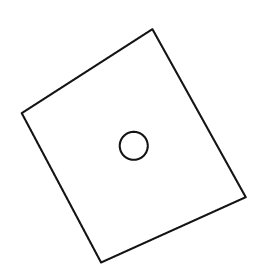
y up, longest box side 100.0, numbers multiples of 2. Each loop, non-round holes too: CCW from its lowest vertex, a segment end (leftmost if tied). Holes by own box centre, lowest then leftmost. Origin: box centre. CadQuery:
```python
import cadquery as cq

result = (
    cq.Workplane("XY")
    .moveTo(-14.0, -50.0)
    .lineTo(48.0, -22.0)
    .lineTo(8.0, 50.0)
    .lineTo(-48.0, 14.0)
    .close()
    .moveTo(0.0, 0.0)
    .circle(6.0)
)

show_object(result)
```